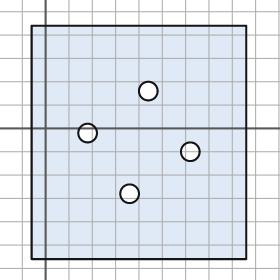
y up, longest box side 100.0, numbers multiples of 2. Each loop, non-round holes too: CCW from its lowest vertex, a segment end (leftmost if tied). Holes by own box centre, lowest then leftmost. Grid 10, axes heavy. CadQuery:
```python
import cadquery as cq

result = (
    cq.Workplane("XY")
    .moveTo(-6.0, -56.0)
    .lineTo(86.0, -56.0)
    .lineTo(86.0, 44.0)
    .lineTo(-6.0, 44.0)
    .close()
    .moveTo(36.0, -28.0)
    .circle(4.0)
    .moveTo(62.0, -10.0)
    .circle(4.0)
    .moveTo(18.0, -2.0)
    .circle(4.0)
    .moveTo(44.0, 16.0)
    .circle(4.0)
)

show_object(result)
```